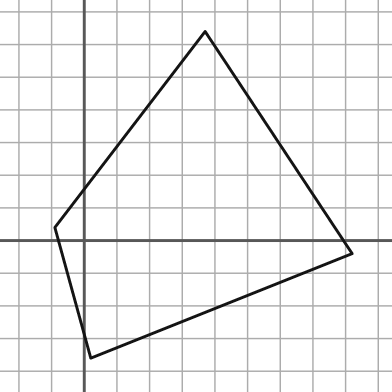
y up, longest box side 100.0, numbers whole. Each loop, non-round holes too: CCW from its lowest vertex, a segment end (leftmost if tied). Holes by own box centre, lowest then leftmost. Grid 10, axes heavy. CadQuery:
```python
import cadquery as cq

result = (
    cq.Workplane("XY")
    .moveTo(2.0, -36.0)
    .lineTo(82.0, -4.0)
    .lineTo(37.0, 64.0)
    .lineTo(-9.0, 4.0)
    .close()
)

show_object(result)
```